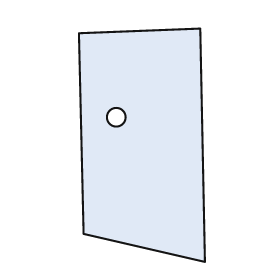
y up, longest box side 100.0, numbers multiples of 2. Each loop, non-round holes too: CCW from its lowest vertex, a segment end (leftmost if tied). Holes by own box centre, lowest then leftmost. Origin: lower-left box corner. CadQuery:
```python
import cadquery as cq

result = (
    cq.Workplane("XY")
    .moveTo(54.0, 0.0)
    .lineTo(52.0, 100.0)
    .lineTo(0.0, 98.0)
    .lineTo(2.0, 12.0)
    .close()
    .moveTo(16.0, 62.0)
    .circle(4.0)
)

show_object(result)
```